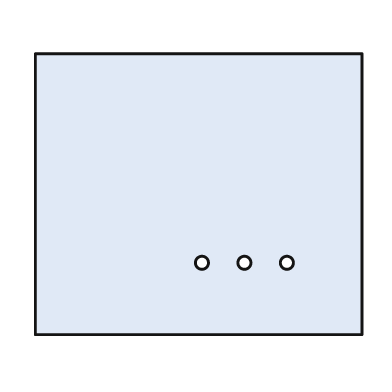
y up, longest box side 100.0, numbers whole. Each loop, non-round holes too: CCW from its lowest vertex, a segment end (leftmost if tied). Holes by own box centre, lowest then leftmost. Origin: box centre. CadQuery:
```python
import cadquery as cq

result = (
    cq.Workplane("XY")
    .moveTo(-50.0, -43.0)
    .lineTo(50.0, -43.0)
    .lineTo(50.0, 43.0)
    .lineTo(-50.0, 43.0)
    .close()
    .moveTo(1.0, -21.0)
    .circle(2.0)
    .moveTo(14.0, -21.0)
    .circle(2.0)
    .moveTo(27.0, -21.0)
    .circle(2.0)
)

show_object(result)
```